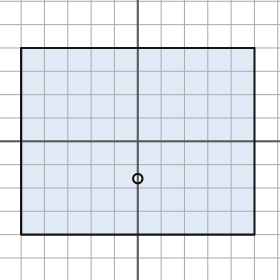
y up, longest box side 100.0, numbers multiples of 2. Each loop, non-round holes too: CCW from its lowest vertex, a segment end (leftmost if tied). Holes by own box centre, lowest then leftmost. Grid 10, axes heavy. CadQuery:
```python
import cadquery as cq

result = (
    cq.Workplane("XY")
    .moveTo(-50.0, -40.0)
    .lineTo(50.0, -40.0)
    .lineTo(50.0, 40.0)
    .lineTo(-50.0, 40.0)
    .close()
    .moveTo(0.0, -16.0)
    .circle(2.0)
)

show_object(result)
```